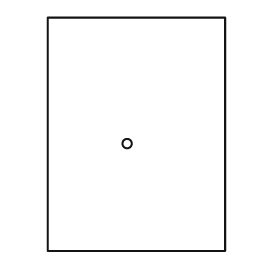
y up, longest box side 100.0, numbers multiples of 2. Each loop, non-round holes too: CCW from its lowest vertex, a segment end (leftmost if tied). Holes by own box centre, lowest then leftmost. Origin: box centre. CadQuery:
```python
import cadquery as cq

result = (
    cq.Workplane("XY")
    .moveTo(-38.0, -50.0)
    .lineTo(38.0, -50.0)
    .lineTo(38.0, 50.0)
    .lineTo(-38.0, 50.0)
    .close()
    .moveTo(-4.0, -4.0)
    .circle(2.0)
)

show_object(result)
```